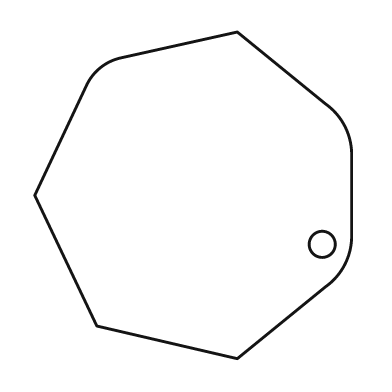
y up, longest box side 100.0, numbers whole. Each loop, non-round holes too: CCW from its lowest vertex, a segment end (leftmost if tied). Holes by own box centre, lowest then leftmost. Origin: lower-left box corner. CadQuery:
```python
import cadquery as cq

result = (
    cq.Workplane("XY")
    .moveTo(62.0, 0.0)
    .lineTo(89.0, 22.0)
    .threePointArc((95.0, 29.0), (97.0, 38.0))
    .lineTo(97.0, 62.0)
    .threePointArc((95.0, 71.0), (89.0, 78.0))
    .lineTo(62.0, 100.0)
    .lineTo(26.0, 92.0)
    .threePointArc((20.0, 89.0), (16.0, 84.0))
    .lineTo(0.0, 50.0)
    .lineTo(19.0, 10.0)
    .close()
    .moveTo(88.0, 35.0)
    .circle(4.0)
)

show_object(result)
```